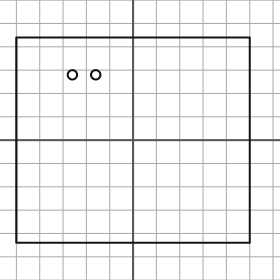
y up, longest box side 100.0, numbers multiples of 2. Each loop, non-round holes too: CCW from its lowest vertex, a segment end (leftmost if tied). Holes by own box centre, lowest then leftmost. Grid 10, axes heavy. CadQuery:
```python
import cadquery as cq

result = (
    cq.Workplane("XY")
    .moveTo(-50.0, -44.0)
    .lineTo(50.0, -44.0)
    .lineTo(50.0, 44.0)
    .lineTo(-50.0, 44.0)
    .close()
    .moveTo(-26.0, 28.0)
    .circle(2.0)
    .moveTo(-16.0, 28.0)
    .circle(2.0)
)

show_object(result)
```